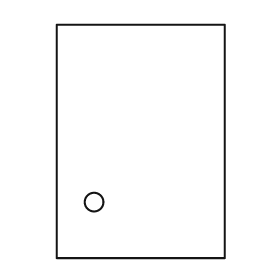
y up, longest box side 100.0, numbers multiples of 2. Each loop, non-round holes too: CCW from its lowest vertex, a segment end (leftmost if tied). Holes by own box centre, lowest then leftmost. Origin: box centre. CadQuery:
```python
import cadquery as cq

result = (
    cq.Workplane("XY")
    .moveTo(-36.0, -50.0)
    .lineTo(36.0, -50.0)
    .lineTo(36.0, 50.0)
    .lineTo(-36.0, 50.0)
    .close()
    .moveTo(-20.0, -26.0)
    .circle(4.0)
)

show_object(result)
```